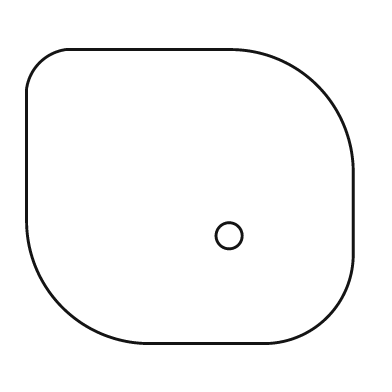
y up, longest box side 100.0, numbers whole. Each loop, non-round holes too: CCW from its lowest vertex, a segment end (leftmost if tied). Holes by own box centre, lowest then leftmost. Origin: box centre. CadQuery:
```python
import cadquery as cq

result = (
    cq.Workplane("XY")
    .moveTo(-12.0, -45.0)
    .lineTo(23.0, -45.0)
    .threePointArc((42.0, -37.0), (50.0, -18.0))
    .lineTo(50.0, 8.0)
    .threePointArc((39.0, 34.0), (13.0, 45.0))
    .lineTo(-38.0, 45.0)
    .threePointArc((-46.0, 41.0), (-50.0, 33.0))
    .lineTo(-50.0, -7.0)
    .threePointArc((-39.0, -34.0), (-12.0, -45.0))
    .close()
    .moveTo(12.0, -12.0)
    .circle(4.0)
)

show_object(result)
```